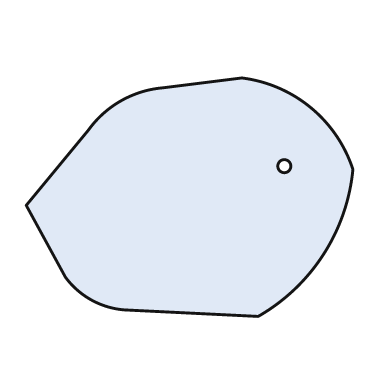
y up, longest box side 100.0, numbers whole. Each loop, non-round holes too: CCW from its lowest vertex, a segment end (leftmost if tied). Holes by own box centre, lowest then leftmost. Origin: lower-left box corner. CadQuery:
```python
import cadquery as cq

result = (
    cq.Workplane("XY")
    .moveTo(71.0, 0.0)
    .threePointArc((91.0, 19.0), (100.0, 45.0))
    .threePointArc((87.0, 64.0), (66.0, 73.0))
    .lineTo(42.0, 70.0)
    .threePointArc((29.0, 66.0), (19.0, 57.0))
    .lineTo(0.0, 34.0)
    .lineTo(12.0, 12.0)
    .threePointArc((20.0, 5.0), (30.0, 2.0))
    .close()
    .moveTo(79.0, 46.0)
    .circle(2.0)
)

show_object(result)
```